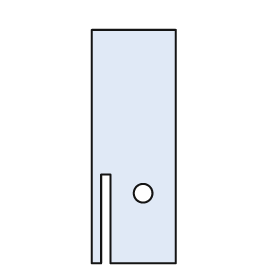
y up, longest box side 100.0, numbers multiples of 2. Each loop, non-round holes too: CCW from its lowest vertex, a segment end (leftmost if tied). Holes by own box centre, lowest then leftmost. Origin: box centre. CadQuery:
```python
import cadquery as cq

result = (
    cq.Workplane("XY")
    .moveTo(-18.0, -50.0)
    .lineTo(-14.0, -50.0)
    .lineTo(-14.0, -12.0)
    .lineTo(-10.0, -12.0)
    .lineTo(-10.0, -50.0)
    .lineTo(18.0, -50.0)
    .lineTo(18.0, 50.0)
    .lineTo(-18.0, 50.0)
    .close()
    .moveTo(4.0, -20.0)
    .circle(4.0)
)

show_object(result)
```